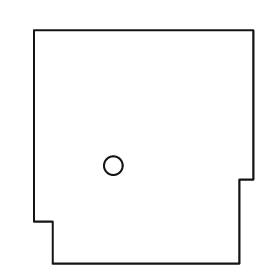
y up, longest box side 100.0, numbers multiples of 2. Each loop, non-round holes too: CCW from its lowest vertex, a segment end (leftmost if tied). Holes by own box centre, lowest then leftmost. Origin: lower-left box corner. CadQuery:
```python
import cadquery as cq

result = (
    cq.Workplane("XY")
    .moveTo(8.0, 0.0)
    .lineTo(88.0, 0.0)
    .lineTo(88.0, 36.0)
    .lineTo(94.0, 36.0)
    .lineTo(94.0, 100.0)
    .lineTo(0.0, 100.0)
    .lineTo(0.0, 18.0)
    .lineTo(8.0, 18.0)
    .close()
    .moveTo(34.0, 42.0)
    .circle(4.0)
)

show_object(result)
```